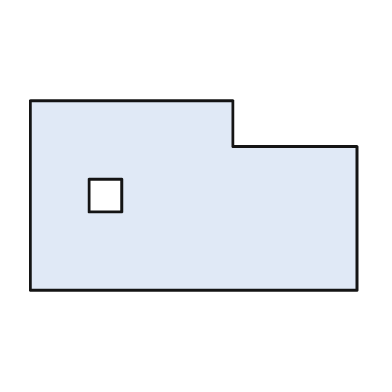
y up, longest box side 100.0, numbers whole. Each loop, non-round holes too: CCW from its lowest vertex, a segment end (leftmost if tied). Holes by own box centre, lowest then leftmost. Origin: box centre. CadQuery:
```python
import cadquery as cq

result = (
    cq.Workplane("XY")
    .moveTo(-50.0, -29.0)
    .lineTo(50.0, -29.0)
    .lineTo(50.0, 15.0)
    .lineTo(12.0, 15.0)
    .lineTo(12.0, 29.0)
    .lineTo(-50.0, 29.0)
    .close()
    .moveTo(-32.0, -5.0)
    .lineTo(-22.0, -5.0)
    .lineTo(-22.0, 5.0)
    .lineTo(-32.0, 5.0)
    .close()
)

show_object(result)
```